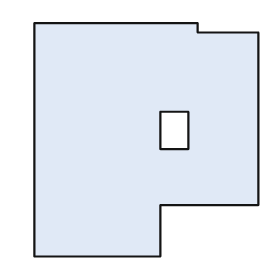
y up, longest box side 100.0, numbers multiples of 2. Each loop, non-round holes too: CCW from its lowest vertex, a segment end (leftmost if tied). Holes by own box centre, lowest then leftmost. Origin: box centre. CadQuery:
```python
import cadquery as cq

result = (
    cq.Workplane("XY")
    .moveTo(-48.0, -50.0)
    .lineTo(6.0, -50.0)
    .lineTo(6.0, -28.0)
    .lineTo(48.0, -28.0)
    .lineTo(48.0, 46.0)
    .lineTo(22.0, 46.0)
    .lineTo(22.0, 50.0)
    .lineTo(-48.0, 50.0)
    .close()
    .moveTo(6.0, -4.0)
    .lineTo(18.0, -4.0)
    .lineTo(18.0, 12.0)
    .lineTo(6.0, 12.0)
    .close()
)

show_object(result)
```